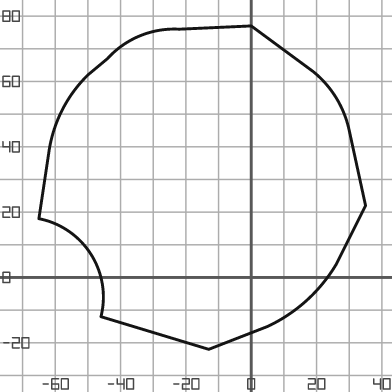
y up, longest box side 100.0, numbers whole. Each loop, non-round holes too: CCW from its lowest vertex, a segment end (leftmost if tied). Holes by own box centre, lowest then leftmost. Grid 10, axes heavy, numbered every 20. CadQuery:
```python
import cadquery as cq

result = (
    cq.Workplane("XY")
    .moveTo(-13.0, -22.0)
    .lineTo(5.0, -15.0)
    .threePointArc((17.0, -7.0), (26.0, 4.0))
    .lineTo(35.0, 22.0)
    .lineTo(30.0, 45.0)
    .threePointArc((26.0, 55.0), (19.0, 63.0))
    .lineTo(0.0, 77.0)
    .lineTo(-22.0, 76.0)
    .threePointArc((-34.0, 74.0), (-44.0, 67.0))
    .lineTo(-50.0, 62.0)
    .threePointArc((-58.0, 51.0), (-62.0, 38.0))
    .lineTo(-65.0, 18.0)
    .threePointArc((-49.0, 7.0), (-46.0, -12.0))
    .close()
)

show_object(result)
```